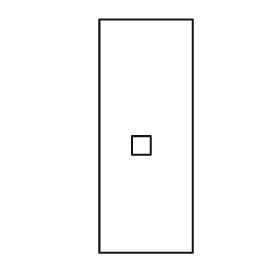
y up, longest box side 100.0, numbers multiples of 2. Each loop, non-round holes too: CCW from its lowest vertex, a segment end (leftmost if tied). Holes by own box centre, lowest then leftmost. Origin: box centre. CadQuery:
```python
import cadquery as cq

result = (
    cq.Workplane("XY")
    .moveTo(-20.0, -50.0)
    .lineTo(20.0, -50.0)
    .lineTo(20.0, 50.0)
    .lineTo(-20.0, 50.0)
    .close()
    .moveTo(-6.0, -8.0)
    .lineTo(2.0, -8.0)
    .lineTo(2.0, 0.0)
    .lineTo(-6.0, 0.0)
    .close()
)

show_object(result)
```